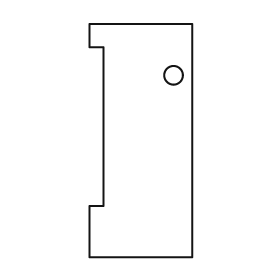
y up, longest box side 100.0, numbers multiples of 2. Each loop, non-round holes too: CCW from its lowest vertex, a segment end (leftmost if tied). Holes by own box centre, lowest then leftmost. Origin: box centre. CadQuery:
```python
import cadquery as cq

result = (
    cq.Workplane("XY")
    .moveTo(-22.0, -50.0)
    .lineTo(22.0, -50.0)
    .lineTo(22.0, 50.0)
    .lineTo(-22.0, 50.0)
    .lineTo(-22.0, 40.0)
    .lineTo(-16.0, 40.0)
    .lineTo(-16.0, -28.0)
    .lineTo(-22.0, -28.0)
    .close()
    .moveTo(14.0, 28.0)
    .circle(4.0)
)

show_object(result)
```